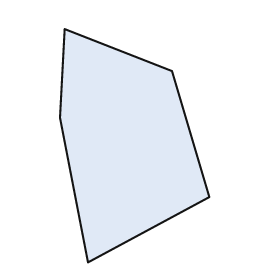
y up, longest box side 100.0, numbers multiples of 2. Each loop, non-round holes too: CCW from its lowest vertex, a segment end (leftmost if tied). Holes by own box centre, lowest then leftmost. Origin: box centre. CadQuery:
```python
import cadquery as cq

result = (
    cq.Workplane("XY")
    .moveTo(-20.0, -50.0)
    .lineTo(32.0, -22.0)
    .lineTo(16.0, 32.0)
    .lineTo(-30.0, 50.0)
    .lineTo(-32.0, 12.0)
    .close()
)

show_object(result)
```